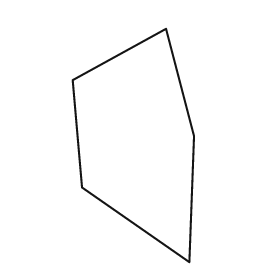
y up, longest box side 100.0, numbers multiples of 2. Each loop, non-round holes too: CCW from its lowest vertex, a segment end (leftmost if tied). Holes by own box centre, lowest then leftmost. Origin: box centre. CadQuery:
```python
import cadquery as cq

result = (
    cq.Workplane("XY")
    .moveTo(24.0, -50.0)
    .lineTo(26.0, 4.0)
    .lineTo(14.0, 50.0)
    .lineTo(-26.0, 28.0)
    .lineTo(-22.0, -18.0)
    .close()
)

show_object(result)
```